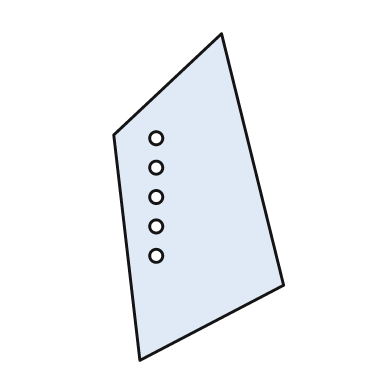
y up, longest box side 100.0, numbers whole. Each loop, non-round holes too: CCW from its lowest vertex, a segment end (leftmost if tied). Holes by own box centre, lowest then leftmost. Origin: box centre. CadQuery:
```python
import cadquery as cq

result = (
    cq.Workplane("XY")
    .moveTo(-18.0, -50.0)
    .lineTo(26.0, -27.0)
    .lineTo(7.0, 50.0)
    .lineTo(-26.0, 19.0)
    .close()
    .moveTo(-13.0, -18.0)
    .circle(2.0)
    .moveTo(-13.0, -9.0)
    .circle(2.0)
    .moveTo(-13.0, 0.0)
    .circle(2.0)
    .moveTo(-13.0, 9.0)
    .circle(2.0)
    .moveTo(-13.0, 18.0)
    .circle(2.0)
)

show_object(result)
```